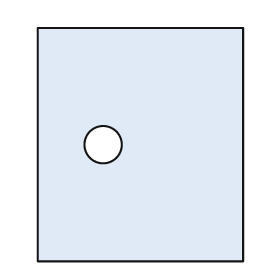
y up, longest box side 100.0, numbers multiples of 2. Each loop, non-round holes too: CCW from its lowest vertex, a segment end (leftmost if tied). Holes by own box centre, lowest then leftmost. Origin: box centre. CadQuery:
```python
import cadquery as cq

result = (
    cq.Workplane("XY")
    .moveTo(-44.0, -50.0)
    .lineTo(44.0, -50.0)
    .lineTo(44.0, 50.0)
    .lineTo(-44.0, 50.0)
    .close()
    .moveTo(-16.0, 0.0)
    .circle(8.0)
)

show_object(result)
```